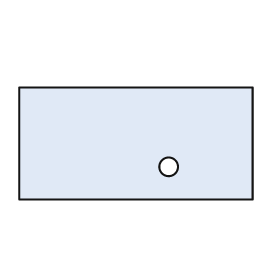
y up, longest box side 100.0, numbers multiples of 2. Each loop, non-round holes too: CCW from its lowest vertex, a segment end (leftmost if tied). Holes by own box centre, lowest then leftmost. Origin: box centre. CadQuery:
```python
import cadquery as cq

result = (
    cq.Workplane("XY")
    .moveTo(-50.0, -24.0)
    .lineTo(50.0, -24.0)
    .lineTo(50.0, 24.0)
    .lineTo(-50.0, 24.0)
    .close()
    .moveTo(14.0, -10.0)
    .circle(4.0)
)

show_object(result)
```